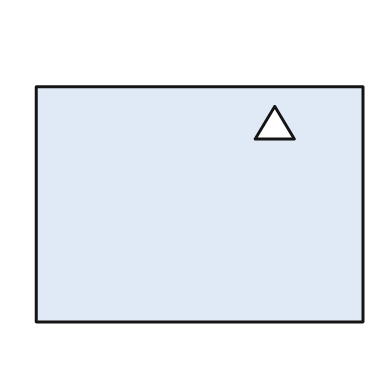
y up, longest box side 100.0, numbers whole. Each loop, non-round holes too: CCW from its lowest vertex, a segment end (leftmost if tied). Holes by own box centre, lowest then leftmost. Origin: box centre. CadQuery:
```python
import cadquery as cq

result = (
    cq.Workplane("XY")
    .moveTo(-50.0, -36.0)
    .lineTo(50.0, -36.0)
    .lineTo(50.0, 36.0)
    .lineTo(-50.0, 36.0)
    .close()
    .moveTo(17.0, 20.0)
    .lineTo(29.0, 20.0)
    .lineTo(23.0, 30.0)
    .close()
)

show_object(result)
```